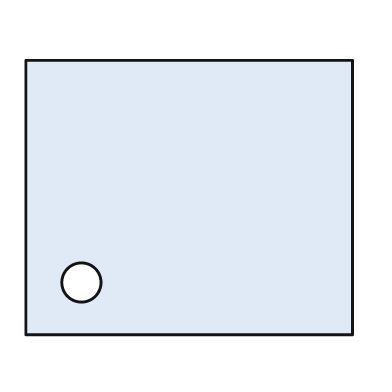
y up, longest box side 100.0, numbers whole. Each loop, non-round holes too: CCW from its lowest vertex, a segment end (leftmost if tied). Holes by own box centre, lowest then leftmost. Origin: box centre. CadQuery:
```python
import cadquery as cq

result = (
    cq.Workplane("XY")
    .moveTo(-50.0, -42.0)
    .lineTo(50.0, -42.0)
    .lineTo(50.0, 42.0)
    .lineTo(-50.0, 42.0)
    .close()
    .moveTo(-33.0, -26.0)
    .circle(6.0)
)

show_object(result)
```